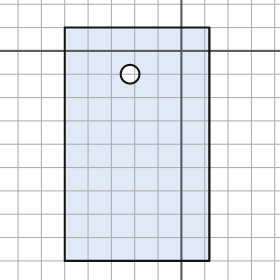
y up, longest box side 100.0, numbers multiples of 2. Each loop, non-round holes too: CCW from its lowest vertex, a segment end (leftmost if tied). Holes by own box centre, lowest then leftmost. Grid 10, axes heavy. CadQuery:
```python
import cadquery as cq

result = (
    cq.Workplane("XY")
    .moveTo(-50.0, -90.0)
    .lineTo(12.0, -90.0)
    .lineTo(12.0, 10.0)
    .lineTo(-50.0, 10.0)
    .close()
    .moveTo(-22.0, -10.0)
    .circle(4.0)
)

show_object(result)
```